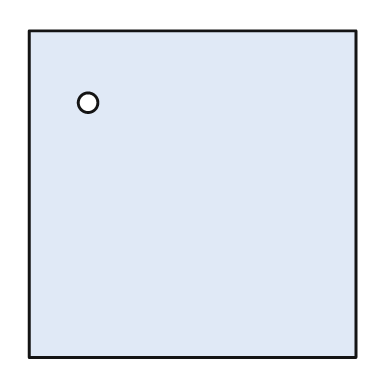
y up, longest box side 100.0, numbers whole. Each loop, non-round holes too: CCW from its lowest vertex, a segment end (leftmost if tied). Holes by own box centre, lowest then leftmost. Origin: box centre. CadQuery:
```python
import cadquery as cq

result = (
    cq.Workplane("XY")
    .moveTo(-50.0, -50.0)
    .lineTo(50.0, -50.0)
    .lineTo(50.0, 50.0)
    .lineTo(-50.0, 50.0)
    .close()
    .moveTo(-32.0, 28.0)
    .circle(3.0)
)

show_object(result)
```